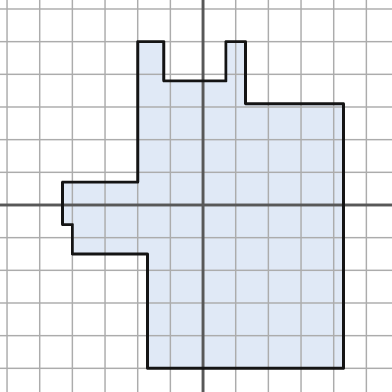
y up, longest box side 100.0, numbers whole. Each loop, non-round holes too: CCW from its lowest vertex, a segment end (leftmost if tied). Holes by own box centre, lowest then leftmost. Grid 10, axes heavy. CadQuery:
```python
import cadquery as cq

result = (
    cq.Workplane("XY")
    .moveTo(-17.0, -50.0)
    .lineTo(43.0, -50.0)
    .lineTo(43.0, 31.0)
    .lineTo(13.0, 31.0)
    .lineTo(13.0, 50.0)
    .lineTo(7.0, 50.0)
    .lineTo(7.0, 38.0)
    .lineTo(-12.0, 38.0)
    .lineTo(-12.0, 50.0)
    .lineTo(-20.0, 50.0)
    .lineTo(-20.0, 7.0)
    .lineTo(-43.0, 7.0)
    .lineTo(-43.0, -6.0)
    .lineTo(-40.0, -6.0)
    .lineTo(-40.0, -15.0)
    .lineTo(-17.0, -15.0)
    .close()
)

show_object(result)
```